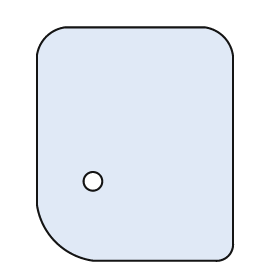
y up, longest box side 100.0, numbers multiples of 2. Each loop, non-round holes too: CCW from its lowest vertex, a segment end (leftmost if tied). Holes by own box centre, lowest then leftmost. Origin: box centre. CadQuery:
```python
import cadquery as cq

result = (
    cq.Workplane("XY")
    .moveTo(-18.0, -50.0)
    .lineTo(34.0, -50.0)
    .threePointArc((40.0, -48.0), (42.0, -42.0))
    .lineTo(42.0, 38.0)
    .threePointArc((38.0, 46.0), (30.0, 50.0))
    .lineTo(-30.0, 50.0)
    .threePointArc((-38.0, 46.0), (-42.0, 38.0))
    .lineTo(-42.0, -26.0)
    .threePointArc((-34.0, -42.0), (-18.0, -50.0))
    .close()
    .moveTo(-18.0, -16.0)
    .circle(4.0)
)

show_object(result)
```